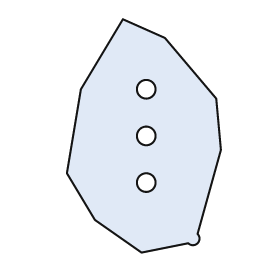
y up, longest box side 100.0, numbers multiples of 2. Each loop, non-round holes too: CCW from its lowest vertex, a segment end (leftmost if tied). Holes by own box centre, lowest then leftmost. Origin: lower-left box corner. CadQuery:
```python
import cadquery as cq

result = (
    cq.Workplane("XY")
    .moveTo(32.0, 0.0)
    .lineTo(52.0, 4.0)
    .threePointArc((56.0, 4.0), (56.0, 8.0))
    .lineTo(66.0, 44.0)
    .lineTo(64.0, 66.0)
    .lineTo(42.0, 92.0)
    .lineTo(24.0, 100.0)
    .lineTo(6.0, 70.0)
    .lineTo(0.0, 34.0)
    .lineTo(12.0, 14.0)
    .close()
    .moveTo(34.0, 30.0)
    .circle(4.0)
    .moveTo(34.0, 50.0)
    .circle(4.0)
    .moveTo(34.0, 70.0)
    .circle(4.0)
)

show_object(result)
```